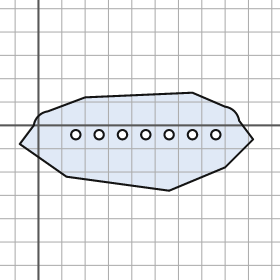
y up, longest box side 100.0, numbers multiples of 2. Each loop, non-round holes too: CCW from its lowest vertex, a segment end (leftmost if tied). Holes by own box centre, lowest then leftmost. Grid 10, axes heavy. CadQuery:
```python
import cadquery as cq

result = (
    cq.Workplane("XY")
    .moveTo(56.0, -28.0)
    .lineTo(80.0, -18.0)
    .lineTo(92.0, -6.0)
    .lineTo(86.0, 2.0)
    .threePointArc((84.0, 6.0), (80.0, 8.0))
    .lineTo(66.0, 14.0)
    .lineTo(20.0, 12.0)
    .lineTo(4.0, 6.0)
    .threePointArc((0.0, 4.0), (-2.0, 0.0))
    .lineTo(-8.0, -8.0)
    .lineTo(12.0, -22.0)
    .close()
    .moveTo(16.0, -4.0)
    .circle(2.0)
    .moveTo(26.0, -4.0)
    .circle(2.0)
    .moveTo(36.0, -4.0)
    .circle(2.0)
    .moveTo(46.0, -4.0)
    .circle(2.0)
    .moveTo(56.0, -4.0)
    .circle(2.0)
    .moveTo(66.0, -4.0)
    .circle(2.0)
    .moveTo(76.0, -4.0)
    .circle(2.0)
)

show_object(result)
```